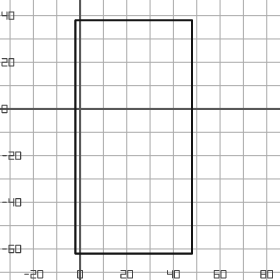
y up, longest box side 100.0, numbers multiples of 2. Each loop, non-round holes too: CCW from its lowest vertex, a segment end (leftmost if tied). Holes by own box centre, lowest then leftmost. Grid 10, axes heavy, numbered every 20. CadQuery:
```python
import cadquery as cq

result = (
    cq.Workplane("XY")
    .moveTo(-2.0, -62.0)
    .lineTo(48.0, -62.0)
    .lineTo(48.0, 38.0)
    .lineTo(-2.0, 38.0)
    .close()
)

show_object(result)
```